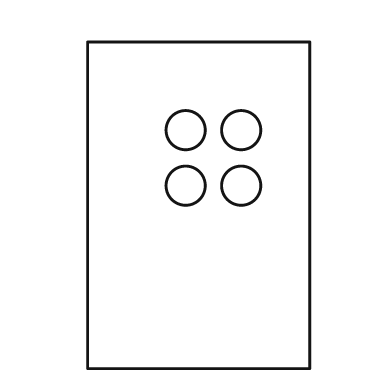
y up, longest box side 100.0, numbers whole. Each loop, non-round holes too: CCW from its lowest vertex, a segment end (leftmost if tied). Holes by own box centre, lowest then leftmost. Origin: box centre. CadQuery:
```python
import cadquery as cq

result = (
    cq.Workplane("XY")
    .moveTo(-34.0, -50.0)
    .lineTo(34.0, -50.0)
    .lineTo(34.0, 50.0)
    .lineTo(-34.0, 50.0)
    .close()
    .moveTo(-4.0, 6.0)
    .circle(6.0)
    .moveTo(13.0, 6.0)
    .circle(6.0)
    .moveTo(-4.0, 23.0)
    .circle(6.0)
    .moveTo(13.0, 23.0)
    .circle(6.0)
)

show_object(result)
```